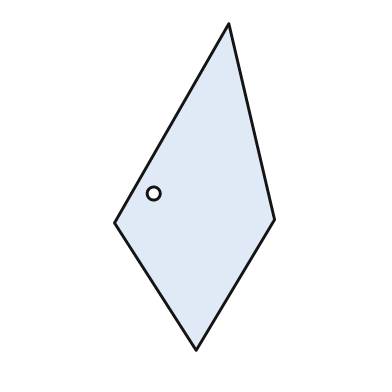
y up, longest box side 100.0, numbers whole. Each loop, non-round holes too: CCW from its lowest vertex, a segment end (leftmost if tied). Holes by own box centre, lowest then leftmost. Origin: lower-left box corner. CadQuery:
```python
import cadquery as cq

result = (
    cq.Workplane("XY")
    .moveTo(25.0, 0.0)
    .lineTo(49.0, 40.0)
    .lineTo(35.0, 100.0)
    .lineTo(0.0, 39.0)
    .close()
    .moveTo(12.0, 48.0)
    .circle(2.0)
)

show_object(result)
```